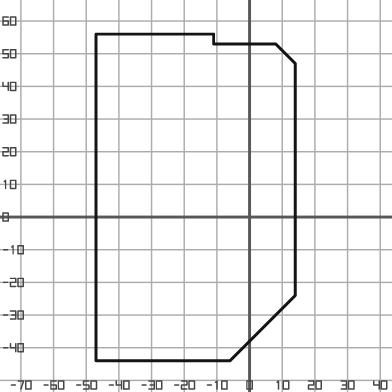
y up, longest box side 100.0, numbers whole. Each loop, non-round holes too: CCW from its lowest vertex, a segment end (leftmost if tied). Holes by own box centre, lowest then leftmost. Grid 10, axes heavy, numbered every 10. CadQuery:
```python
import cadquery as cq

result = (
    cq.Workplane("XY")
    .moveTo(-47.0, -44.0)
    .lineTo(-6.0, -44.0)
    .lineTo(14.0, -24.0)
    .lineTo(14.0, 47.0)
    .lineTo(8.0, 53.0)
    .lineTo(-11.0, 53.0)
    .lineTo(-11.0, 56.0)
    .lineTo(-47.0, 56.0)
    .close()
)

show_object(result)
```